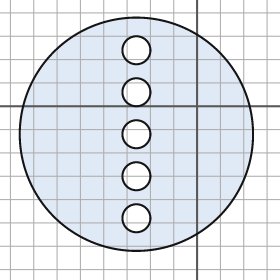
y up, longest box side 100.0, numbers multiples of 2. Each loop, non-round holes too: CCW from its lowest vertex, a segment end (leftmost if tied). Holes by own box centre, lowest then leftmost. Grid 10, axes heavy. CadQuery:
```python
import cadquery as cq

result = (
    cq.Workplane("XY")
    .moveTo(-26.0, -12.0)
    .circle(50.0)
    .moveTo(-26.0, -48.0)
    .circle(6.0)
    .moveTo(-26.0, -30.0)
    .circle(6.0)
    .moveTo(-26.0, -12.0)
    .circle(6.0)
    .moveTo(-26.0, 6.0)
    .circle(6.0)
    .moveTo(-26.0, 24.0)
    .circle(6.0)
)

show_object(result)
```